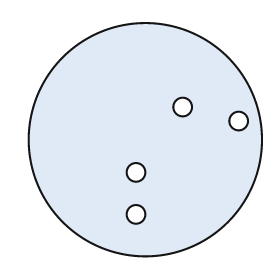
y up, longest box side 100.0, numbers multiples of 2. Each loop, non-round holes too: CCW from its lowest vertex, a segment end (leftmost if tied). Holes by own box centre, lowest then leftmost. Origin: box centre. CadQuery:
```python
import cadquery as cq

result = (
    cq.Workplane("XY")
    .moveTo(0.0, 0.0)
    .circle(50.0)
    .moveTo(-4.0, -32.0)
    .circle(4.0)
    .moveTo(-4.0, -14.0)
    .circle(4.0)
    .moveTo(40.0, 8.0)
    .circle(4.0)
    .moveTo(16.0, 14.0)
    .circle(4.0)
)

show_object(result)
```